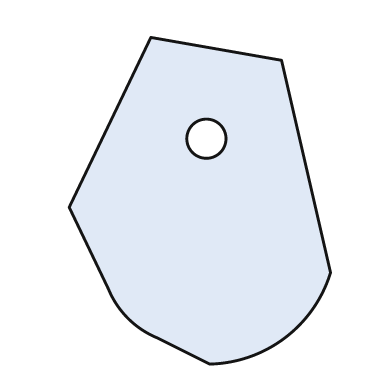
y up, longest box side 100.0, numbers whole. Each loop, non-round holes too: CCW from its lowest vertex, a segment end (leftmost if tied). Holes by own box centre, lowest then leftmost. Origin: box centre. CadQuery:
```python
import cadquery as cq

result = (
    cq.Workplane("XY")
    .moveTo(3.0, -50.0)
    .threePointArc((26.0, -42.0), (40.0, -22.0))
    .lineTo(25.0, 43.0)
    .lineTo(-15.0, 50.0)
    .lineTo(-40.0, -2.0)
    .lineTo(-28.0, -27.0)
    .threePointArc((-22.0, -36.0), (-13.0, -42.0))
    .close()
    .moveTo(2.0, 19.0)
    .circle(6.0)
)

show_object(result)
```